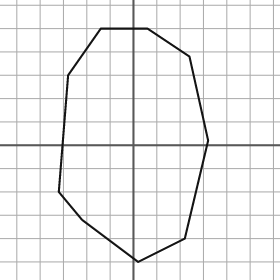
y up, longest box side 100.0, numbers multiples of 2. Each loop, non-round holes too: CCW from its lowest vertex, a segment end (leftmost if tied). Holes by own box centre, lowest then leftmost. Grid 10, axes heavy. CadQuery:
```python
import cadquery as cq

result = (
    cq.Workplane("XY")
    .moveTo(2.0, -50.0)
    .lineTo(22.0, -40.0)
    .lineTo(32.0, 2.0)
    .lineTo(24.0, 38.0)
    .lineTo(6.0, 50.0)
    .lineTo(-14.0, 50.0)
    .lineTo(-28.0, 30.0)
    .lineTo(-32.0, -20.0)
    .lineTo(-22.0, -32.0)
    .close()
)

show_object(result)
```